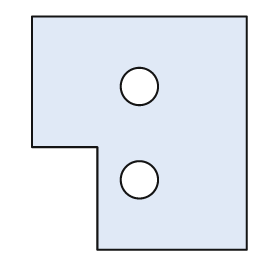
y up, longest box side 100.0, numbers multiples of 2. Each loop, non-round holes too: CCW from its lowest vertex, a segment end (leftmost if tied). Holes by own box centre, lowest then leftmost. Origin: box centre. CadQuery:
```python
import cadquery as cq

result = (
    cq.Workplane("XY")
    .moveTo(-18.0, -50.0)
    .lineTo(46.0, -50.0)
    .lineTo(46.0, 50.0)
    .lineTo(-46.0, 50.0)
    .lineTo(-46.0, -6.0)
    .lineTo(-18.0, -6.0)
    .close()
    .moveTo(0.0, -20.0)
    .circle(8.0)
    .moveTo(0.0, 20.0)
    .circle(8.0)
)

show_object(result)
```